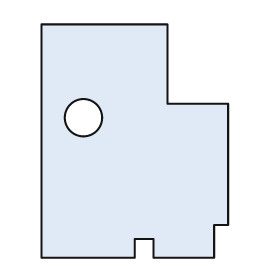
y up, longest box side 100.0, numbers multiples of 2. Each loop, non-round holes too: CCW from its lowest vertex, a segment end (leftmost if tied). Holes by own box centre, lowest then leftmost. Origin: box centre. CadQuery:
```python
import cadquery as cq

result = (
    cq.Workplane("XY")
    .moveTo(-40.0, -50.0)
    .lineTo(0.0, -50.0)
    .lineTo(0.0, -42.0)
    .lineTo(8.0, -42.0)
    .lineTo(8.0, -50.0)
    .lineTo(34.0, -50.0)
    .lineTo(34.0, -36.0)
    .lineTo(40.0, -36.0)
    .lineTo(40.0, 16.0)
    .lineTo(14.0, 16.0)
    .lineTo(14.0, 50.0)
    .lineTo(-40.0, 50.0)
    .close()
    .moveTo(-22.0, 10.0)
    .circle(8.0)
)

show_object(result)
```